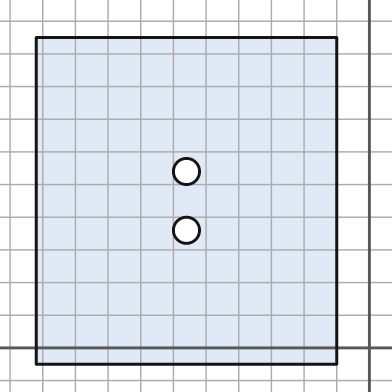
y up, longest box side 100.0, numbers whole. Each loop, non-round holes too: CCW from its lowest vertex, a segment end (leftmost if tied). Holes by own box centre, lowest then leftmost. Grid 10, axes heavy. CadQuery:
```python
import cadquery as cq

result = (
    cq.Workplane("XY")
    .moveTo(-102.0, -5.0)
    .lineTo(-10.0, -5.0)
    .lineTo(-10.0, 95.0)
    .lineTo(-102.0, 95.0)
    .close()
    .moveTo(-56.0, 36.0)
    .circle(4.0)
    .moveTo(-56.0, 54.0)
    .circle(4.0)
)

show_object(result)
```